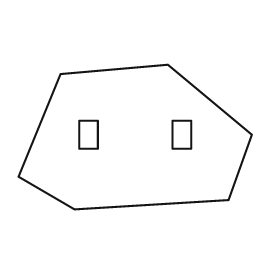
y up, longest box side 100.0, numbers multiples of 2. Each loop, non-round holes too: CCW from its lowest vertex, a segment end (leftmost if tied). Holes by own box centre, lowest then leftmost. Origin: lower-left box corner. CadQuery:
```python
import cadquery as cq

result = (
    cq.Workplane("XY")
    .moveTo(24.0, 0.0)
    .lineTo(90.0, 4.0)
    .lineTo(100.0, 32.0)
    .lineTo(64.0, 62.0)
    .lineTo(18.0, 58.0)
    .lineTo(0.0, 14.0)
    .close()
    .moveTo(26.0, 26.0)
    .lineTo(34.0, 26.0)
    .lineTo(34.0, 38.0)
    .lineTo(26.0, 38.0)
    .close()
    .moveTo(66.0, 26.0)
    .lineTo(74.0, 26.0)
    .lineTo(74.0, 38.0)
    .lineTo(66.0, 38.0)
    .close()
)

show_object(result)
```